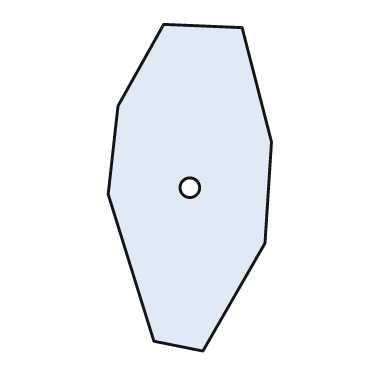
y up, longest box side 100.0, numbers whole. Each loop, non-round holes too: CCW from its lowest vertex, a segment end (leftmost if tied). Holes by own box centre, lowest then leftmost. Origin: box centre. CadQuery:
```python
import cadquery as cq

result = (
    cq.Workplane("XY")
    .moveTo(4.0, -50.0)
    .lineTo(23.0, -17.0)
    .lineTo(25.0, 14.0)
    .lineTo(16.0, 49.0)
    .lineTo(-8.0, 50.0)
    .lineTo(-22.0, 25.0)
    .lineTo(-25.0, -2.0)
    .lineTo(-11.0, -47.0)
    .close()
    .moveTo(0.0, 0.0)
    .circle(3.0)
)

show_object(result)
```